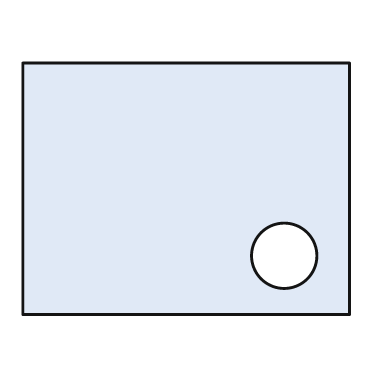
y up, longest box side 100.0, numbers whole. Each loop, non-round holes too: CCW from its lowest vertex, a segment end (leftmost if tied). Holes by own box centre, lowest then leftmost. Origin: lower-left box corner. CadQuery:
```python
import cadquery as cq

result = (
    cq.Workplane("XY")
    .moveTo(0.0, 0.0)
    .lineTo(100.0, 0.0)
    .lineTo(100.0, 77.0)
    .lineTo(0.0, 77.0)
    .close()
    .moveTo(80.0, 18.0)
    .circle(10.0)
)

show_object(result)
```